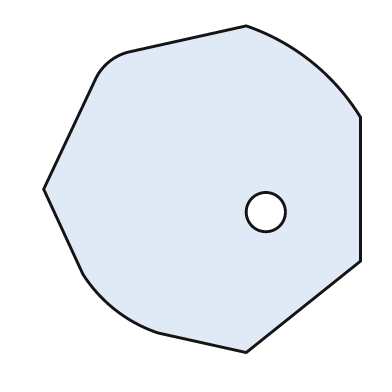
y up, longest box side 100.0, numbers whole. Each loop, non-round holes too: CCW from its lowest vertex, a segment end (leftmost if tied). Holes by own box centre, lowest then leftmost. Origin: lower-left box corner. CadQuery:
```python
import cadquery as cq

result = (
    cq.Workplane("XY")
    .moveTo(62.0, 0.0)
    .lineTo(97.0, 28.0)
    .lineTo(97.0, 72.0)
    .threePointArc((82.0, 89.0), (62.0, 100.0))
    .lineTo(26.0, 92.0)
    .threePointArc((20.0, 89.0), (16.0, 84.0))
    .lineTo(0.0, 50.0)
    .lineTo(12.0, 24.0)
    .threePointArc((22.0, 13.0), (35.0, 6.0))
    .close()
    .moveTo(68.0, 43.0)
    .circle(6.0)
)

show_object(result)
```